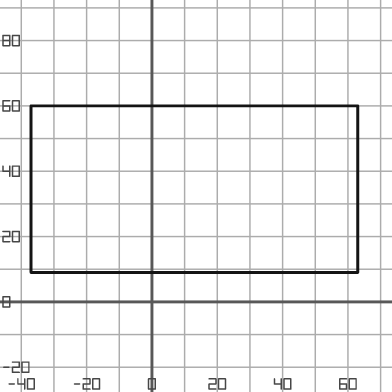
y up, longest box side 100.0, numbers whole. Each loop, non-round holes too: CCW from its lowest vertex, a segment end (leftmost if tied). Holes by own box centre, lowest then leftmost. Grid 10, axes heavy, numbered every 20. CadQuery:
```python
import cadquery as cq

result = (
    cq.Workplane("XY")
    .moveTo(-37.0, 9.0)
    .lineTo(63.0, 9.0)
    .lineTo(63.0, 60.0)
    .lineTo(-37.0, 60.0)
    .close()
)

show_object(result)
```